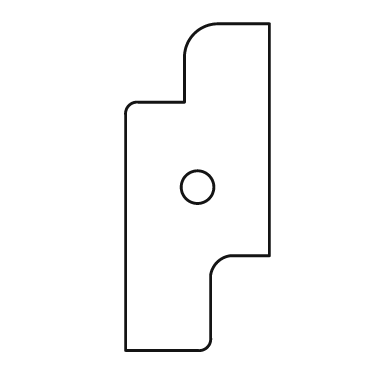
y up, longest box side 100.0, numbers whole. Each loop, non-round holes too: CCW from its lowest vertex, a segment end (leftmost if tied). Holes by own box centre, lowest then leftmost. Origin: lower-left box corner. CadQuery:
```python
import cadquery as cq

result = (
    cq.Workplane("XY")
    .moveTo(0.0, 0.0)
    .lineTo(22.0, 0.0)
    .threePointArc((25.0, 1.0), (26.0, 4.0))
    .lineTo(26.0, 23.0)
    .threePointArc((28.0, 27.0), (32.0, 29.0))
    .lineTo(44.0, 29.0)
    .lineTo(44.0, 100.0)
    .lineTo(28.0, 100.0)
    .threePointArc((21.0, 97.0), (18.0, 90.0))
    .lineTo(18.0, 76.0)
    .lineTo(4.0, 76.0)
    .threePointArc((1.0, 75.0), (0.0, 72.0))
    .close()
    .moveTo(22.0, 50.0)
    .circle(5.0)
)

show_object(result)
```